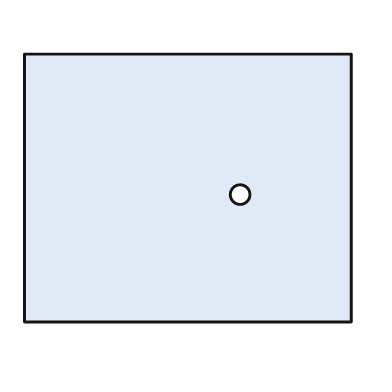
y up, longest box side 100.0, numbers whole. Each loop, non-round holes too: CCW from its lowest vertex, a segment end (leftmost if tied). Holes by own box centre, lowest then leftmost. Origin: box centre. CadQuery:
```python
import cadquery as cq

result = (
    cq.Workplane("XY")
    .moveTo(-50.0, -41.0)
    .lineTo(50.0, -41.0)
    .lineTo(50.0, 41.0)
    .lineTo(-50.0, 41.0)
    .close()
    .moveTo(16.0, -2.0)
    .circle(3.0)
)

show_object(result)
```